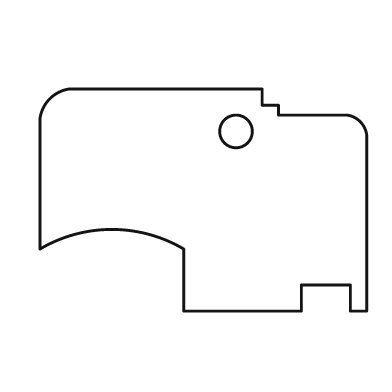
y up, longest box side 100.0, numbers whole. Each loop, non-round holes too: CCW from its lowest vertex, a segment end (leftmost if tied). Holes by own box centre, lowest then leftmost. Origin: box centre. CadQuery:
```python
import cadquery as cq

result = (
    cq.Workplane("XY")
    .moveTo(-6.0, -34.0)
    .lineTo(30.0, -34.0)
    .lineTo(30.0, -26.0)
    .lineTo(45.0, -26.0)
    .lineTo(45.0, -34.0)
    .lineTo(50.0, -34.0)
    .lineTo(50.0, 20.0)
    .threePointArc((48.0, 24.0), (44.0, 26.0))
    .lineTo(23.0, 26.0)
    .lineTo(23.0, 29.0)
    .lineTo(18.0, 29.0)
    .lineTo(18.0, 34.0)
    .lineTo(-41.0, 34.0)
    .threePointArc((-47.0, 31.0), (-50.0, 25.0))
    .lineTo(-50.0, -15.0)
    .threePointArc((-28.0, -9.0), (-6.0, -15.0))
    .close()
    .moveTo(10.0, 21.0)
    .circle(5.0)
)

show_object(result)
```